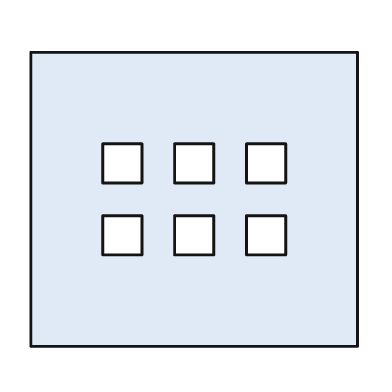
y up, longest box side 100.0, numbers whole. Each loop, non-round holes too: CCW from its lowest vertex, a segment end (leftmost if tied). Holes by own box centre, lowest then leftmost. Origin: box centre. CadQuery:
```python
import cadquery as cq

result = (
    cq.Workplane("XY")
    .moveTo(-50.0, -45.0)
    .lineTo(50.0, -45.0)
    .lineTo(50.0, 45.0)
    .lineTo(-50.0, 45.0)
    .close()
    .moveTo(-28.0, -17.0)
    .lineTo(-16.0, -17.0)
    .lineTo(-16.0, -5.0)
    .lineTo(-28.0, -5.0)
    .close()
    .moveTo(-6.0, -17.0)
    .lineTo(6.0, -17.0)
    .lineTo(6.0, -5.0)
    .lineTo(-6.0, -5.0)
    .close()
    .moveTo(16.0, -17.0)
    .lineTo(28.0, -17.0)
    .lineTo(28.0, -5.0)
    .lineTo(16.0, -5.0)
    .close()
    .moveTo(-28.0, 5.0)
    .lineTo(-16.0, 5.0)
    .lineTo(-16.0, 17.0)
    .lineTo(-28.0, 17.0)
    .close()
    .moveTo(-6.0, 5.0)
    .lineTo(6.0, 5.0)
    .lineTo(6.0, 17.0)
    .lineTo(-6.0, 17.0)
    .close()
    .moveTo(16.0, 5.0)
    .lineTo(28.0, 5.0)
    .lineTo(28.0, 17.0)
    .lineTo(16.0, 17.0)
    .close()
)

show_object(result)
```